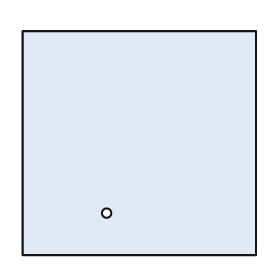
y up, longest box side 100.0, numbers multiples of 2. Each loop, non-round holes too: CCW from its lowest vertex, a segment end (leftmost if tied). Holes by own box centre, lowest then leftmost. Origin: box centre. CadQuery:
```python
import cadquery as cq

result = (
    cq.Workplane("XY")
    .moveTo(-50.0, -48.0)
    .lineTo(50.0, -48.0)
    .lineTo(50.0, 48.0)
    .lineTo(-50.0, 48.0)
    .close()
    .moveTo(-14.0, -30.0)
    .circle(2.0)
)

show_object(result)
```